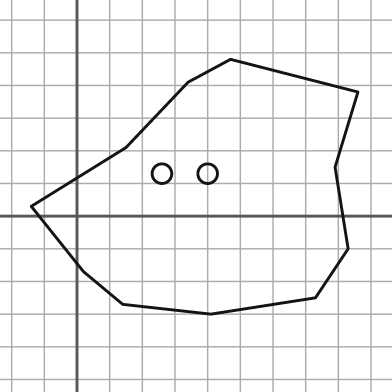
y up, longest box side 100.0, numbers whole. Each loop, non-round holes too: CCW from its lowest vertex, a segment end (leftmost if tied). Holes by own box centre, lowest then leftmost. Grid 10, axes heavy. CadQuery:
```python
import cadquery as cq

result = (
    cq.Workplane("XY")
    .moveTo(41.0, -30.0)
    .lineTo(73.0, -25.0)
    .lineTo(83.0, -10.0)
    .lineTo(79.0, 15.0)
    .lineTo(86.0, 38.0)
    .lineTo(47.0, 48.0)
    .lineTo(34.0, 41.0)
    .lineTo(15.0, 21.0)
    .lineTo(-14.0, 3.0)
    .lineTo(2.0, -17.0)
    .lineTo(14.0, -27.0)
    .close()
    .moveTo(26.0, 13.0)
    .circle(3.0)
    .moveTo(40.0, 13.0)
    .circle(3.0)
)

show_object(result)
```